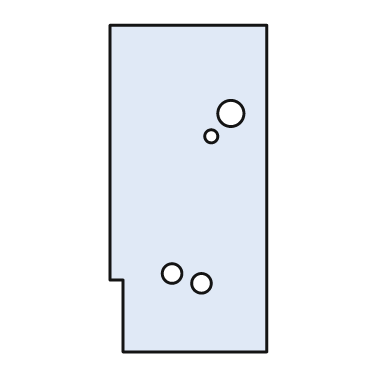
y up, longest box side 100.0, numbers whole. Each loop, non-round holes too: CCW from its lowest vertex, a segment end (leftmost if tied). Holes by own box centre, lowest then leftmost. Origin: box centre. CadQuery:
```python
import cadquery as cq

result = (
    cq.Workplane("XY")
    .moveTo(-20.0, -50.0)
    .lineTo(24.0, -50.0)
    .lineTo(24.0, 50.0)
    .lineTo(-24.0, 50.0)
    .lineTo(-24.0, -28.0)
    .lineTo(-20.0, -28.0)
    .close()
    .moveTo(4.0, -29.0)
    .circle(3.0)
    .moveTo(-5.0, -26.0)
    .circle(3.0)
    .moveTo(7.0, 16.0)
    .circle(2.0)
    .moveTo(13.0, 23.0)
    .circle(4.0)
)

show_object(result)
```